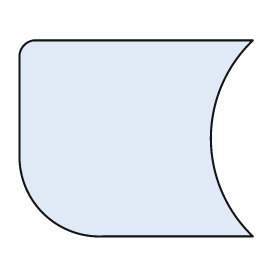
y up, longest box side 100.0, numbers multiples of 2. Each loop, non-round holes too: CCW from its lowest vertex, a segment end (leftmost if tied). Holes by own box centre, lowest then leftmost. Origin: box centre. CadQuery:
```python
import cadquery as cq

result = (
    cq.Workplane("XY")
    .moveTo(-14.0, -42.0)
    .lineTo(50.0, -42.0)
    .threePointArc((32.0, 0.0), (50.0, 42.0))
    .lineTo(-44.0, 42.0)
    .threePointArc((-48.0, 40.0), (-50.0, 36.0))
    .lineTo(-50.0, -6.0)
    .threePointArc((-40.0, -32.0), (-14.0, -42.0))
    .close()
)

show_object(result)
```